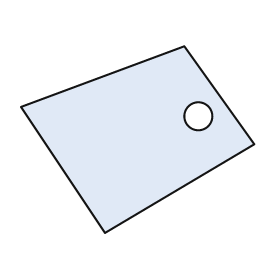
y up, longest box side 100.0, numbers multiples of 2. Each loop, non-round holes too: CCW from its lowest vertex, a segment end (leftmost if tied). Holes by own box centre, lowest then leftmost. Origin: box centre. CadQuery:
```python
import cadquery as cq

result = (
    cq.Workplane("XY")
    .moveTo(-14.0, -40.0)
    .lineTo(50.0, -2.0)
    .lineTo(20.0, 40.0)
    .lineTo(-50.0, 14.0)
    .close()
    .moveTo(26.0, 10.0)
    .circle(6.0)
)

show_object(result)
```